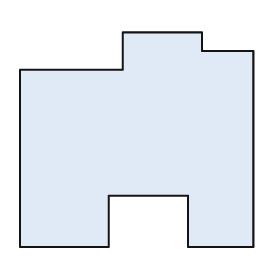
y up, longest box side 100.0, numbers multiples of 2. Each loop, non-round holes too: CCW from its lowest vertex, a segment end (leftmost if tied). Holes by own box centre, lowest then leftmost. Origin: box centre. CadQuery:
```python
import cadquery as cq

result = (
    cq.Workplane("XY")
    .moveTo(-50.0, -46.0)
    .lineTo(-12.0, -46.0)
    .lineTo(-12.0, -24.0)
    .lineTo(22.0, -24.0)
    .lineTo(22.0, -46.0)
    .lineTo(50.0, -46.0)
    .lineTo(50.0, 38.0)
    .lineTo(28.0, 38.0)
    .lineTo(28.0, 46.0)
    .lineTo(-6.0, 46.0)
    .lineTo(-6.0, 30.0)
    .lineTo(-50.0, 30.0)
    .close()
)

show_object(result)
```